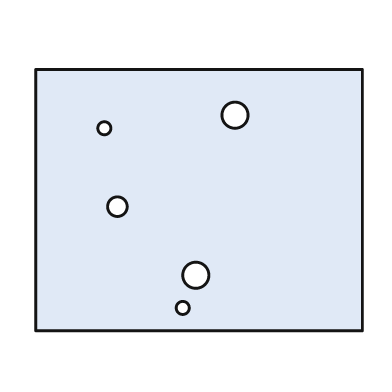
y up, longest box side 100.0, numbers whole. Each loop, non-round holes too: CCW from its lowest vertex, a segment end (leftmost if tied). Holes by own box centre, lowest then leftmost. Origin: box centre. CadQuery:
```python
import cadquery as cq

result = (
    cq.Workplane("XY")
    .moveTo(-50.0, -40.0)
    .lineTo(50.0, -40.0)
    .lineTo(50.0, 40.0)
    .lineTo(-50.0, 40.0)
    .close()
    .moveTo(-5.0, -33.0)
    .circle(2.0)
    .moveTo(-1.0, -23.0)
    .circle(4.0)
    .moveTo(-25.0, -2.0)
    .circle(3.0)
    .moveTo(-29.0, 22.0)
    .circle(2.0)
    .moveTo(11.0, 26.0)
    .circle(4.0)
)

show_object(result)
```